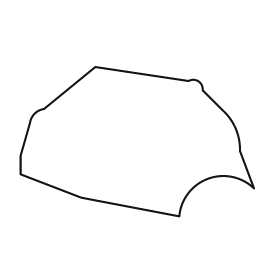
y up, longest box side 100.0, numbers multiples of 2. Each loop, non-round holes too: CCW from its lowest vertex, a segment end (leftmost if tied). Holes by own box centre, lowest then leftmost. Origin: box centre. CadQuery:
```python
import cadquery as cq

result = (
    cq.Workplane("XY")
    .moveTo(18.0, -32.0)
    .threePointArc((30.0, -16.0), (50.0, -20.0))
    .lineTo(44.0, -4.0)
    .threePointArc((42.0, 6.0), (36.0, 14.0))
    .lineTo(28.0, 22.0)
    .threePointArc((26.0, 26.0), (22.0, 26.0))
    .lineTo(-18.0, 32.0)
    .lineTo(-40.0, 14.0)
    .threePointArc((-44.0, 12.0), (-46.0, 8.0))
    .lineTo(-50.0, -6.0)
    .lineTo(-50.0, -14.0)
    .lineTo(-24.0, -24.0)
    .close()
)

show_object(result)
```